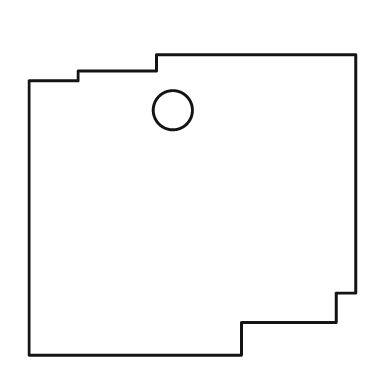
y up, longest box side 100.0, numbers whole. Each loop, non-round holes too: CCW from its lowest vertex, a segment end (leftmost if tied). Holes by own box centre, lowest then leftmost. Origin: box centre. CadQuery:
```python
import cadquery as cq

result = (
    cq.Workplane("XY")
    .moveTo(-50.0, -46.0)
    .lineTo(15.0, -46.0)
    .lineTo(15.0, -36.0)
    .lineTo(44.0, -36.0)
    .lineTo(44.0, -27.0)
    .lineTo(50.0, -27.0)
    .lineTo(50.0, 46.0)
    .lineTo(-11.0, 46.0)
    .lineTo(-11.0, 41.0)
    .lineTo(-35.0, 41.0)
    .lineTo(-35.0, 38.0)
    .lineTo(-50.0, 38.0)
    .close()
    .moveTo(-6.0, 29.0)
    .circle(6.0)
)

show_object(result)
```